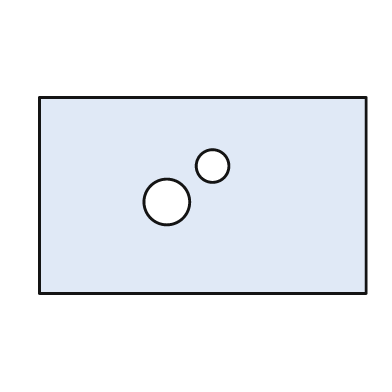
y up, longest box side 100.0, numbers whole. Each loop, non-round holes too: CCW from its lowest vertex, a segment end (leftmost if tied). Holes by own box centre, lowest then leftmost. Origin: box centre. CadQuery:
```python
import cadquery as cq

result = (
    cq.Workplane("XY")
    .moveTo(-50.0, -30.0)
    .lineTo(50.0, -30.0)
    .lineTo(50.0, 30.0)
    .lineTo(-50.0, 30.0)
    .close()
    .moveTo(-11.0, -2.0)
    .circle(7.0)
    .moveTo(3.0, 9.0)
    .circle(5.0)
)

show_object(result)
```